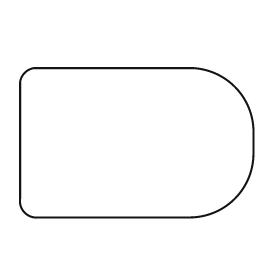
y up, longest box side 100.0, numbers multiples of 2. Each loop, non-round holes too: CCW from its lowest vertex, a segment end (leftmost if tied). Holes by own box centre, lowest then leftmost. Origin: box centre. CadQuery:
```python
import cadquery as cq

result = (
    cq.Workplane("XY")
    .moveTo(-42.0, -32.0)
    .lineTo(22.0, -32.0)
    .threePointArc((42.0, -24.0), (50.0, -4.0))
    .lineTo(50.0, 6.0)
    .threePointArc((42.0, 24.0), (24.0, 32.0))
    .lineTo(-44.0, 32.0)
    .threePointArc((-48.0, 30.0), (-50.0, 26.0))
    .lineTo(-50.0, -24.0)
    .threePointArc((-48.0, -30.0), (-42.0, -32.0))
    .close()
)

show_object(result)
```